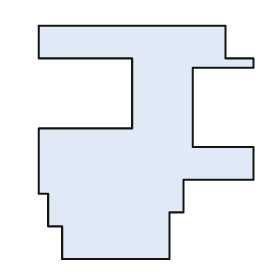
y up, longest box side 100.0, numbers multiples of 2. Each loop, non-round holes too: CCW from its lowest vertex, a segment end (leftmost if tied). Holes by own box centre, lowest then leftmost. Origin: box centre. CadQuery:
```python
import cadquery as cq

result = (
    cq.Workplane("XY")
    .moveTo(-36.0, -50.0)
    .lineTo(10.0, -50.0)
    .lineTo(10.0, -30.0)
    .lineTo(16.0, -30.0)
    .lineTo(16.0, -16.0)
    .lineTo(46.0, -16.0)
    .lineTo(46.0, -2.0)
    .lineTo(20.0, -2.0)
    .lineTo(20.0, 32.0)
    .lineTo(46.0, 32.0)
    .lineTo(46.0, 36.0)
    .lineTo(34.0, 36.0)
    .lineTo(34.0, 50.0)
    .lineTo(-46.0, 50.0)
    .lineTo(-46.0, 36.0)
    .lineTo(-6.0, 36.0)
    .lineTo(-6.0, 6.0)
    .lineTo(-46.0, 6.0)
    .lineTo(-46.0, -22.0)
    .lineTo(-42.0, -22.0)
    .lineTo(-42.0, -36.0)
    .lineTo(-36.0, -36.0)
    .close()
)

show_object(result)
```